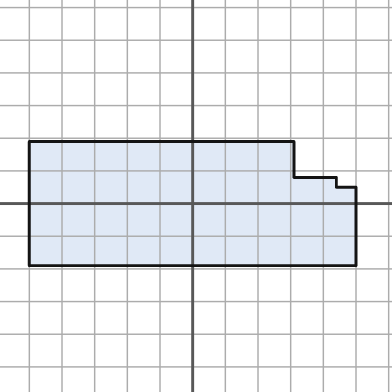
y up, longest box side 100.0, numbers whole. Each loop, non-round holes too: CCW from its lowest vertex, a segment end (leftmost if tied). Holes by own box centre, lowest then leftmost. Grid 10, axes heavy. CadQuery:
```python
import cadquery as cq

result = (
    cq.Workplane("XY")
    .moveTo(-50.0, -19.0)
    .lineTo(50.0, -19.0)
    .lineTo(50.0, 5.0)
    .lineTo(44.0, 5.0)
    .lineTo(44.0, 8.0)
    .lineTo(31.0, 8.0)
    .lineTo(31.0, 19.0)
    .lineTo(-50.0, 19.0)
    .close()
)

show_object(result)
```